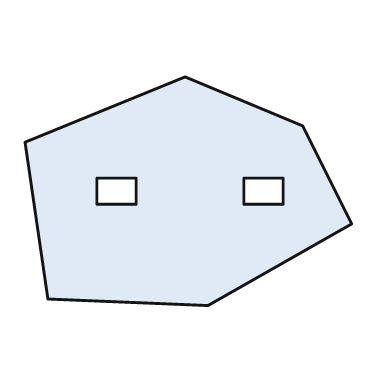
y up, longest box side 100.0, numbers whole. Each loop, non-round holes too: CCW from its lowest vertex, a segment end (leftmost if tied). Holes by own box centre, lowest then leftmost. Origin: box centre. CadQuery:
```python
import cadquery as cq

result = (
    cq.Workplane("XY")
    .moveTo(6.0, -35.0)
    .lineTo(50.0, -10.0)
    .lineTo(35.0, 20.0)
    .lineTo(-1.0, 35.0)
    .lineTo(-50.0, 15.0)
    .lineTo(-43.0, -33.0)
    .close()
    .moveTo(-28.0, -4.0)
    .lineTo(-16.0, -4.0)
    .lineTo(-16.0, 4.0)
    .lineTo(-28.0, 4.0)
    .close()
    .moveTo(17.0, -4.0)
    .lineTo(29.0, -4.0)
    .lineTo(29.0, 4.0)
    .lineTo(17.0, 4.0)
    .close()
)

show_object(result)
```